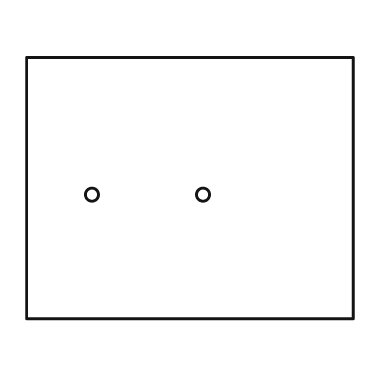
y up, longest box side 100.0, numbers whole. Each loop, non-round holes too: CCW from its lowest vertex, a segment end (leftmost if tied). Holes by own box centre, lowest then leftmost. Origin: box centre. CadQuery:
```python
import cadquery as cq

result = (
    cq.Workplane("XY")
    .moveTo(-50.0, -40.0)
    .lineTo(50.0, -40.0)
    .lineTo(50.0, 40.0)
    .lineTo(-50.0, 40.0)
    .close()
    .moveTo(-30.0, -2.0)
    .circle(2.0)
    .moveTo(4.0, -2.0)
    .circle(2.0)
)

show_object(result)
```